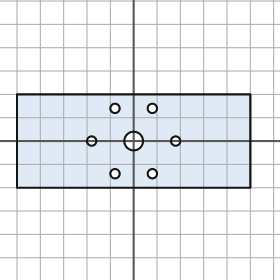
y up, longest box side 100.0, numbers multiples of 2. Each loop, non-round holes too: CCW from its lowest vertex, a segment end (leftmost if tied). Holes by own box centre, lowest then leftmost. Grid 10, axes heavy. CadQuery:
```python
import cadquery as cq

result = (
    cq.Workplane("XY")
    .moveTo(-50.0, -20.0)
    .lineTo(50.0, -20.0)
    .lineTo(50.0, 20.0)
    .lineTo(-50.0, 20.0)
    .close()
    .moveTo(-8.0, -14.0)
    .circle(2.0)
    .moveTo(8.0, -14.0)
    .circle(2.0)
    .moveTo(-18.0, 0.0)
    .circle(2.0)
    .moveTo(0.0, 0.0)
    .circle(4.0)
    .moveTo(18.0, 0.0)
    .circle(2.0)
    .moveTo(-8.0, 14.0)
    .circle(2.0)
    .moveTo(8.0, 14.0)
    .circle(2.0)
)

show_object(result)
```